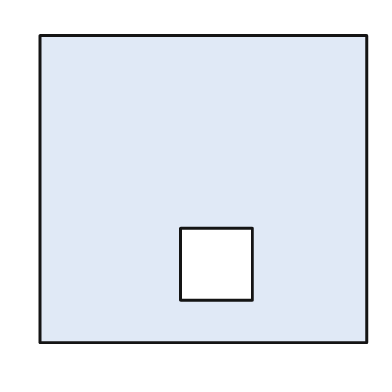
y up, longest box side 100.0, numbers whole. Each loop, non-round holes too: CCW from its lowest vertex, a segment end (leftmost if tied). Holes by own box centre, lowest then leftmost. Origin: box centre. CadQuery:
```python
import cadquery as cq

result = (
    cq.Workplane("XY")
    .moveTo(-50.0, -47.0)
    .lineTo(50.0, -47.0)
    .lineTo(50.0, 47.0)
    .lineTo(-50.0, 47.0)
    .close()
    .moveTo(-7.0, -34.0)
    .lineTo(15.0, -34.0)
    .lineTo(15.0, -12.0)
    .lineTo(-7.0, -12.0)
    .close()
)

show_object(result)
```